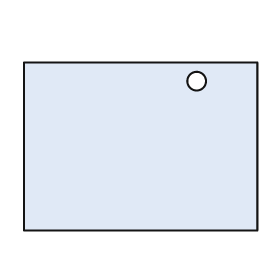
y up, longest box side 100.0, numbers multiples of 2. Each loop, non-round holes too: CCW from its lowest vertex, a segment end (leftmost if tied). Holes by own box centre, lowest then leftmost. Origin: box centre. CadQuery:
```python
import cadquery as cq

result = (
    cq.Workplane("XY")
    .moveTo(-50.0, -36.0)
    .lineTo(50.0, -36.0)
    .lineTo(50.0, 36.0)
    .lineTo(-50.0, 36.0)
    .close()
    .moveTo(24.0, 28.0)
    .circle(4.0)
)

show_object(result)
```